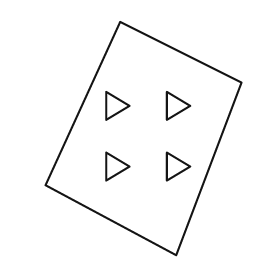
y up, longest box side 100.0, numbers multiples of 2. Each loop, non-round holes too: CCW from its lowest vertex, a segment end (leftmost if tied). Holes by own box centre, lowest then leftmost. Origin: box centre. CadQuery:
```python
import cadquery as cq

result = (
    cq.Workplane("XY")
    .moveTo(14.0, -50.0)
    .lineTo(42.0, 24.0)
    .lineTo(-10.0, 50.0)
    .lineTo(-42.0, -20.0)
    .close()
    .moveTo(-16.0, -18.0)
    .lineTo(-6.0, -12.0)
    .lineTo(-16.0, -6.0)
    .close()
    .moveTo(10.0, -18.0)
    .lineTo(20.0, -12.0)
    .lineTo(10.0, -6.0)
    .close()
    .moveTo(-16.0, 8.0)
    .lineTo(-6.0, 14.0)
    .lineTo(-16.0, 20.0)
    .close()
    .moveTo(10.0, 8.0)
    .lineTo(20.0, 14.0)
    .lineTo(10.0, 20.0)
    .close()
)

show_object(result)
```